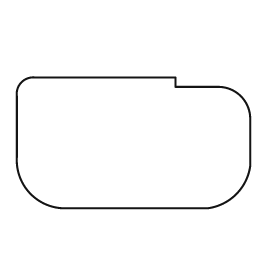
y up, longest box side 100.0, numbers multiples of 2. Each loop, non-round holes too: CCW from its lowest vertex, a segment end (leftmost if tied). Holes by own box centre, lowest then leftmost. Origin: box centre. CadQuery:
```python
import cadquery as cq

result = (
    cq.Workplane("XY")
    .moveTo(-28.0, -28.0)
    .lineTo(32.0, -28.0)
    .threePointArc((44.0, -22.0), (50.0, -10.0))
    .lineTo(50.0, 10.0)
    .threePointArc((46.0, 20.0), (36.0, 24.0))
    .lineTo(18.0, 24.0)
    .lineTo(18.0, 28.0)
    .lineTo(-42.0, 28.0)
    .threePointArc((-48.0, 26.0), (-50.0, 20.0))
    .lineTo(-50.0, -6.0)
    .threePointArc((-44.0, -22.0), (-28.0, -28.0))
    .close()
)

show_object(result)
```